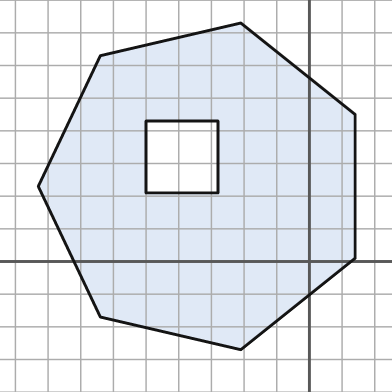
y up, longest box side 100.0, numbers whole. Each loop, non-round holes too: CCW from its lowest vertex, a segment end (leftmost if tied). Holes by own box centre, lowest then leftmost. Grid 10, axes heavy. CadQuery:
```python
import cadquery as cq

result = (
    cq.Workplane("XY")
    .moveTo(-21.0, -27.0)
    .lineTo(14.0, 1.0)
    .lineTo(14.0, 45.0)
    .lineTo(-21.0, 73.0)
    .lineTo(-64.0, 63.0)
    .lineTo(-83.0, 23.0)
    .lineTo(-64.0, -17.0)
    .close()
    .moveTo(-50.0, 21.0)
    .lineTo(-28.0, 21.0)
    .lineTo(-28.0, 43.0)
    .lineTo(-50.0, 43.0)
    .close()
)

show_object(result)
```